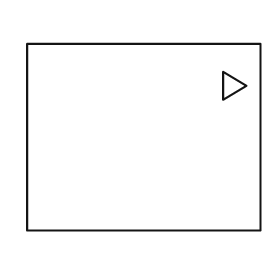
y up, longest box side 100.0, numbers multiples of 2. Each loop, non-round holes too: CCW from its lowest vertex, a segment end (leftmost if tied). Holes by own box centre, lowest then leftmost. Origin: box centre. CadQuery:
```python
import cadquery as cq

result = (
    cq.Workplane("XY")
    .moveTo(-50.0, -40.0)
    .lineTo(50.0, -40.0)
    .lineTo(50.0, 40.0)
    .lineTo(-50.0, 40.0)
    .close()
    .moveTo(34.0, 16.0)
    .lineTo(44.0, 22.0)
    .lineTo(34.0, 28.0)
    .close()
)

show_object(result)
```